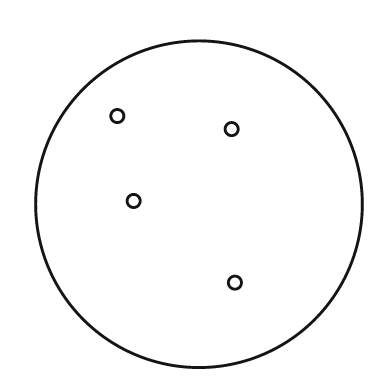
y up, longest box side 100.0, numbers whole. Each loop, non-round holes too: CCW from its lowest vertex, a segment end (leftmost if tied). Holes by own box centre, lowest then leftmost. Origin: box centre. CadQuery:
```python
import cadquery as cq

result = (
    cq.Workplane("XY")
    .moveTo(0.0, 0.0)
    .circle(50.0)
    .moveTo(11.0, -24.0)
    .circle(2.0)
    .moveTo(-20.0, 1.0)
    .circle(2.0)
    .moveTo(10.0, 23.0)
    .circle(2.0)
    .moveTo(-25.0, 27.0)
    .circle(2.0)
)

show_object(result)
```